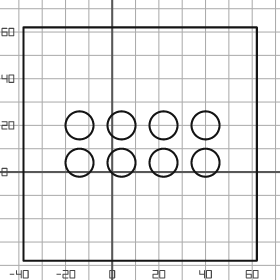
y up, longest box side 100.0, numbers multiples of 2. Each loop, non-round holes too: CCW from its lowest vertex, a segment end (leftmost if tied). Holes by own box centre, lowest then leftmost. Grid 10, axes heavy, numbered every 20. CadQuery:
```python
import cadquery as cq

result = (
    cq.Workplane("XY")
    .moveTo(-38.0, -38.0)
    .lineTo(62.0, -38.0)
    .lineTo(62.0, 62.0)
    .lineTo(-38.0, 62.0)
    .close()
    .moveTo(-14.0, 4.0)
    .circle(6.0)
    .moveTo(4.0, 4.0)
    .circle(6.0)
    .moveTo(22.0, 4.0)
    .circle(6.0)
    .moveTo(40.0, 4.0)
    .circle(6.0)
    .moveTo(-14.0, 20.0)
    .circle(6.0)
    .moveTo(4.0, 20.0)
    .circle(6.0)
    .moveTo(22.0, 20.0)
    .circle(6.0)
    .moveTo(40.0, 20.0)
    .circle(6.0)
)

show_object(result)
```